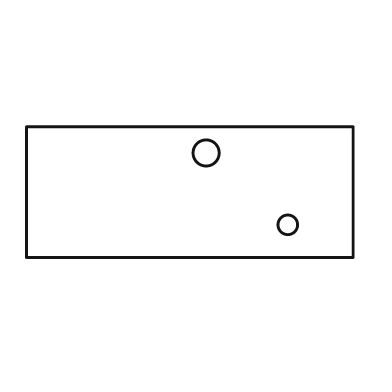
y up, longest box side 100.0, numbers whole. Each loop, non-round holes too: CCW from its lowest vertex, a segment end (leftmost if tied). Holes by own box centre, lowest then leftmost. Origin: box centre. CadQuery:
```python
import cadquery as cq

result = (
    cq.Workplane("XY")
    .moveTo(-50.0, -20.0)
    .lineTo(50.0, -20.0)
    .lineTo(50.0, 20.0)
    .lineTo(-50.0, 20.0)
    .close()
    .moveTo(30.0, -10.0)
    .circle(3.0)
    .moveTo(5.0, 12.0)
    .circle(4.0)
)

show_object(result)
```